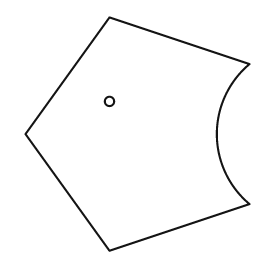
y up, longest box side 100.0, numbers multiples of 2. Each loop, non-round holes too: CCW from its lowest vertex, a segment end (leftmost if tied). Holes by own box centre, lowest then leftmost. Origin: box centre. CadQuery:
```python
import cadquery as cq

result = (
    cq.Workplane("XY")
    .moveTo(-12.0, -50.0)
    .lineTo(48.0, -30.0)
    .threePointArc((34.0, 0.0), (48.0, 30.0))
    .lineTo(-12.0, 50.0)
    .lineTo(-48.0, 0.0)
    .close()
    .moveTo(-12.0, 14.0)
    .circle(2.0)
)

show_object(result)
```